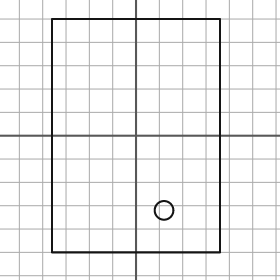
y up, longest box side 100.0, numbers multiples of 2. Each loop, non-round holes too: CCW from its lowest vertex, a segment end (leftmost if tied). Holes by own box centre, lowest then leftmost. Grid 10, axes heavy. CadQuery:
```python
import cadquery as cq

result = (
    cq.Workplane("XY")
    .moveTo(-36.0, -50.0)
    .lineTo(36.0, -50.0)
    .lineTo(36.0, 50.0)
    .lineTo(-36.0, 50.0)
    .close()
    .moveTo(12.0, -32.0)
    .circle(4.0)
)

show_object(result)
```